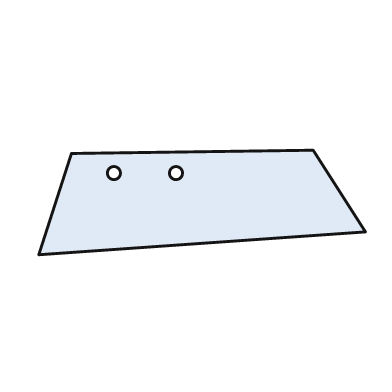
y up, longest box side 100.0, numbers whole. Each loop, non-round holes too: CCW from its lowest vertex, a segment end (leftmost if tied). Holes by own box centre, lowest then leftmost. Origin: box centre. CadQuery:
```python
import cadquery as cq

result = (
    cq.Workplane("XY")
    .moveTo(-50.0, -16.0)
    .lineTo(50.0, -9.0)
    .lineTo(34.0, 16.0)
    .lineTo(-40.0, 15.0)
    .close()
    .moveTo(-27.0, 9.0)
    .circle(2.0)
    .moveTo(-8.0, 9.0)
    .circle(2.0)
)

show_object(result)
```